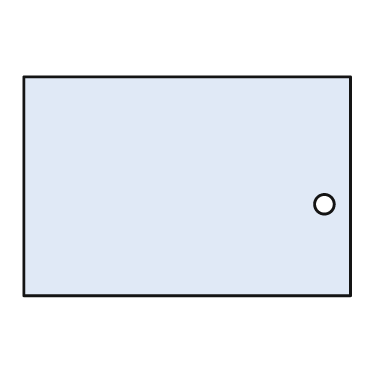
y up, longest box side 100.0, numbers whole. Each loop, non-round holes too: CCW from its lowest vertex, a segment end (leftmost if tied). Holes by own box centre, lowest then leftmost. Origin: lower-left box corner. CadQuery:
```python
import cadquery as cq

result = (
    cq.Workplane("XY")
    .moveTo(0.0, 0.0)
    .lineTo(100.0, 0.0)
    .lineTo(100.0, 67.0)
    .lineTo(0.0, 67.0)
    .close()
    .moveTo(92.0, 28.0)
    .circle(3.0)
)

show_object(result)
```